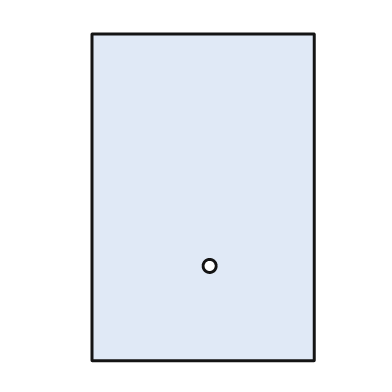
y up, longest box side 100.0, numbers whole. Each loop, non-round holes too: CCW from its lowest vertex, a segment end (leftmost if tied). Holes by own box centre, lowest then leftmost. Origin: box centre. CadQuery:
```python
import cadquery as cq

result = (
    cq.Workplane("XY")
    .moveTo(-34.0, -50.0)
    .lineTo(34.0, -50.0)
    .lineTo(34.0, 50.0)
    .lineTo(-34.0, 50.0)
    .close()
    .moveTo(2.0, -21.0)
    .circle(2.0)
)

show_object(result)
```